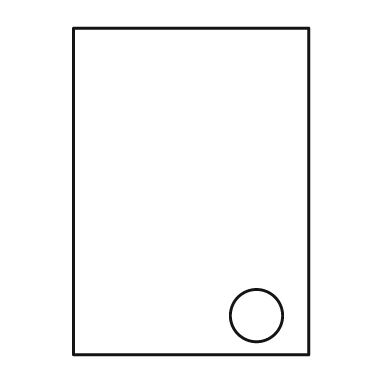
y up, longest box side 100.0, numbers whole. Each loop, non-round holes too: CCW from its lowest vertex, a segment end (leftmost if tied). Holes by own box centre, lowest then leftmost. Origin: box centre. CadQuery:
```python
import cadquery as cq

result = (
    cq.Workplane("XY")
    .moveTo(-36.0, -50.0)
    .lineTo(36.0, -50.0)
    .lineTo(36.0, 50.0)
    .lineTo(-36.0, 50.0)
    .close()
    .moveTo(20.0, -38.0)
    .circle(8.0)
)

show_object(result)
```